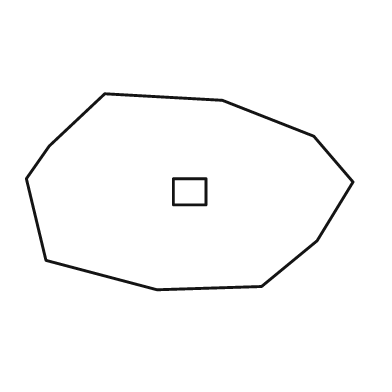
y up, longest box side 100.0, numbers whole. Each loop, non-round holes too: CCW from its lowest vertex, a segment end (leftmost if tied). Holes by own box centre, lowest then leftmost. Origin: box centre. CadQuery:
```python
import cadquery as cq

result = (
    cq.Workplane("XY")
    .moveTo(-10.0, -30.0)
    .lineTo(22.0, -29.0)
    .lineTo(39.0, -15.0)
    .lineTo(50.0, 3.0)
    .lineTo(38.0, 17.0)
    .lineTo(10.0, 28.0)
    .lineTo(-26.0, 30.0)
    .lineTo(-43.0, 14.0)
    .lineTo(-50.0, 4.0)
    .lineTo(-44.0, -21.0)
    .close()
    .moveTo(-5.0, -4.0)
    .lineTo(5.0, -4.0)
    .lineTo(5.0, 4.0)
    .lineTo(-5.0, 4.0)
    .close()
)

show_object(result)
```